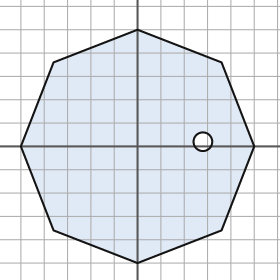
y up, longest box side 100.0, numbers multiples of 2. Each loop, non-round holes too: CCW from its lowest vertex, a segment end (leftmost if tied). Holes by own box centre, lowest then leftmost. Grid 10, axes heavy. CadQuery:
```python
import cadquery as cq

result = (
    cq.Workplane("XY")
    .moveTo(0.0, -50.0)
    .lineTo(36.0, -36.0)
    .lineTo(50.0, 0.0)
    .lineTo(36.0, 36.0)
    .lineTo(0.0, 50.0)
    .lineTo(-36.0, 36.0)
    .lineTo(-50.0, 0.0)
    .lineTo(-36.0, -36.0)
    .close()
    .moveTo(28.0, 2.0)
    .circle(4.0)
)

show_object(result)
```